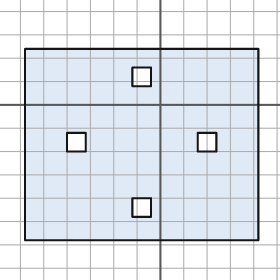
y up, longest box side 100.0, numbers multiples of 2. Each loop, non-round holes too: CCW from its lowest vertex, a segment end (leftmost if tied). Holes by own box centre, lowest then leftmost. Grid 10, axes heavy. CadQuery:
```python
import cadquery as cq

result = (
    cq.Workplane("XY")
    .moveTo(-58.0, -58.0)
    .lineTo(42.0, -58.0)
    .lineTo(42.0, 24.0)
    .lineTo(-58.0, 24.0)
    .close()
    .moveTo(-12.0, -48.0)
    .lineTo(-4.0, -48.0)
    .lineTo(-4.0, -40.0)
    .lineTo(-12.0, -40.0)
    .close()
    .moveTo(-40.0, -20.0)
    .lineTo(-32.0, -20.0)
    .lineTo(-32.0, -12.0)
    .lineTo(-40.0, -12.0)
    .close()
    .moveTo(16.0, -20.0)
    .lineTo(24.0, -20.0)
    .lineTo(24.0, -12.0)
    .lineTo(16.0, -12.0)
    .close()
    .moveTo(-12.0, 8.0)
    .lineTo(-4.0, 8.0)
    .lineTo(-4.0, 16.0)
    .lineTo(-12.0, 16.0)
    .close()
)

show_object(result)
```